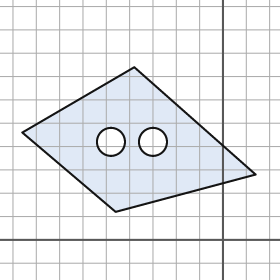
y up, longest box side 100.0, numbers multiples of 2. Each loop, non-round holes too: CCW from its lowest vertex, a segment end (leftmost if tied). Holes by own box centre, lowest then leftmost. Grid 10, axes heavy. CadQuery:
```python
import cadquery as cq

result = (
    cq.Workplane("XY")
    .moveTo(-46.0, 12.0)
    .lineTo(14.0, 28.0)
    .lineTo(-38.0, 74.0)
    .lineTo(-86.0, 46.0)
    .close()
    .moveTo(-48.0, 42.0)
    .circle(6.0)
    .moveTo(-30.0, 42.0)
    .circle(6.0)
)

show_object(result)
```